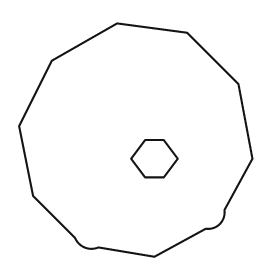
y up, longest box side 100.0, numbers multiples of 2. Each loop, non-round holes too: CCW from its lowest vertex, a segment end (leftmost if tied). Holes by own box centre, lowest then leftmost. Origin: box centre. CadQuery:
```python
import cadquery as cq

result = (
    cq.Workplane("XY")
    .moveTo(8.0, -50.0)
    .lineTo(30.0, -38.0)
    .threePointArc((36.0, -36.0), (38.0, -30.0))
    .lineTo(50.0, -8.0)
    .lineTo(44.0, 24.0)
    .lineTo(22.0, 46.0)
    .lineTo(-8.0, 50.0)
    .lineTo(-36.0, 34.0)
    .lineTo(-50.0, 6.0)
    .lineTo(-44.0, -24.0)
    .lineTo(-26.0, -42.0)
    .threePointArc((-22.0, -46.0), (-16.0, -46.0))
    .close()
    .moveTo(4.0, -16.0)
    .lineTo(12.0, -16.0)
    .lineTo(18.0, -8.0)
    .lineTo(12.0, 0.0)
    .lineTo(4.0, 0.0)
    .lineTo(-2.0, -8.0)
    .close()
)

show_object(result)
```